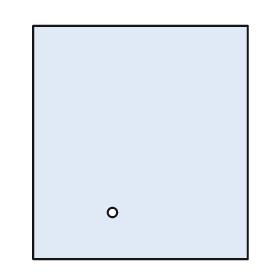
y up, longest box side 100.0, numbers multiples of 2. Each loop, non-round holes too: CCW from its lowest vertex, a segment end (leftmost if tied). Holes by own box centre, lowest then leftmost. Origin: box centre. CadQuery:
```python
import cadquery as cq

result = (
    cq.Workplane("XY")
    .moveTo(-46.0, -50.0)
    .lineTo(46.0, -50.0)
    .lineTo(46.0, 50.0)
    .lineTo(-46.0, 50.0)
    .close()
    .moveTo(-12.0, -30.0)
    .circle(2.0)
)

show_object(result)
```